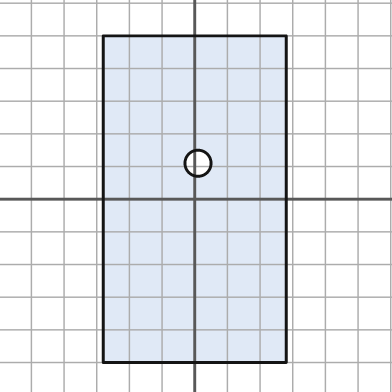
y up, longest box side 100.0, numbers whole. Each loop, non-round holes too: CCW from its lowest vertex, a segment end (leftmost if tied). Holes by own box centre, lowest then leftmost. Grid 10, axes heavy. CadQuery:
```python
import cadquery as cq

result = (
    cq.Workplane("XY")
    .moveTo(-28.0, -50.0)
    .lineTo(28.0, -50.0)
    .lineTo(28.0, 50.0)
    .lineTo(-28.0, 50.0)
    .close()
    .moveTo(1.0, 11.0)
    .circle(4.0)
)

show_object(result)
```